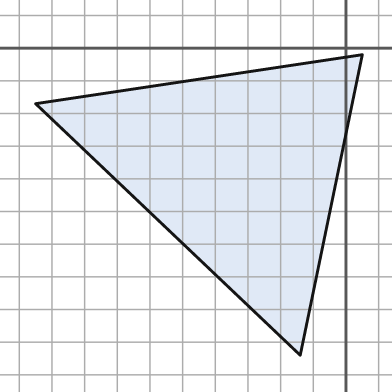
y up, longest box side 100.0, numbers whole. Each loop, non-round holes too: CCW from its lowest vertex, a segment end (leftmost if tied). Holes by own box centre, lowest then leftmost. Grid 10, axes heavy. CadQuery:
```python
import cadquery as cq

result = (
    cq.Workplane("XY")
    .moveTo(-14.0, -94.0)
    .lineTo(5.0, -2.0)
    .lineTo(-95.0, -17.0)
    .close()
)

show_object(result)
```